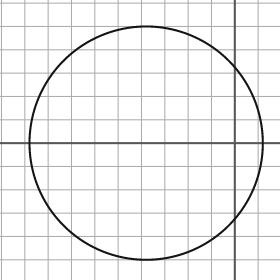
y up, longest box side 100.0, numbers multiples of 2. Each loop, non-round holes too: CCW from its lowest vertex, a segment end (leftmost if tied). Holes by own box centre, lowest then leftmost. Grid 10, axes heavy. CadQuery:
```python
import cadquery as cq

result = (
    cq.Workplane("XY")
    .moveTo(-38.0, 0.0)
    .circle(50.0)
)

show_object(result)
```